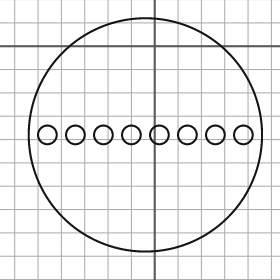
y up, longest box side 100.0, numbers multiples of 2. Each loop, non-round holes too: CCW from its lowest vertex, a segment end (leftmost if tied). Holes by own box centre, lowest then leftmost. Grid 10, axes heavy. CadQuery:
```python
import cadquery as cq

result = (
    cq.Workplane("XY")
    .moveTo(-4.0, -38.0)
    .circle(50.0)
    .moveTo(-46.0, -38.0)
    .circle(4.0)
    .moveTo(-34.0, -38.0)
    .circle(4.0)
    .moveTo(-22.0, -38.0)
    .circle(4.0)
    .moveTo(-10.0, -38.0)
    .circle(4.0)
    .moveTo(2.0, -38.0)
    .circle(4.0)
    .moveTo(14.0, -38.0)
    .circle(4.0)
    .moveTo(26.0, -38.0)
    .circle(4.0)
    .moveTo(38.0, -38.0)
    .circle(4.0)
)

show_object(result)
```